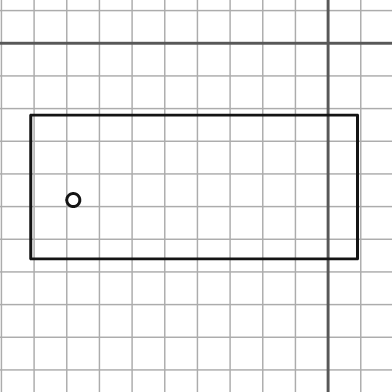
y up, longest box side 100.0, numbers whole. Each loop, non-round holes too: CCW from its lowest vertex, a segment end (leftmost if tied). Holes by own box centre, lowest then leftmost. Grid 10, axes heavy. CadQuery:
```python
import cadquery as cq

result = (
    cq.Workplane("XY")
    .moveTo(-91.0, -66.0)
    .lineTo(9.0, -66.0)
    .lineTo(9.0, -22.0)
    .lineTo(-91.0, -22.0)
    .close()
    .moveTo(-78.0, -48.0)
    .circle(2.0)
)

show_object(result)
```